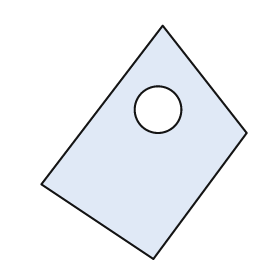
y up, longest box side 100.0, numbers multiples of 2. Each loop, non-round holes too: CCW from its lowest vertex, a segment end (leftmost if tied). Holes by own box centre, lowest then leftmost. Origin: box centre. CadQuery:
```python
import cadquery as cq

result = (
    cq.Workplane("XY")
    .moveTo(4.0, -50.0)
    .lineTo(44.0, 4.0)
    .lineTo(8.0, 50.0)
    .lineTo(-44.0, -18.0)
    .close()
    .moveTo(6.0, 14.0)
    .circle(10.0)
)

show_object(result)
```